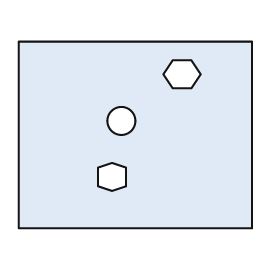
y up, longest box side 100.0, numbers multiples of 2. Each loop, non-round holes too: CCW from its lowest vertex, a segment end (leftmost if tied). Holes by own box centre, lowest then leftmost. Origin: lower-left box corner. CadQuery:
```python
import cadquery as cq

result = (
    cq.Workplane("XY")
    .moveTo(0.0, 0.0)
    .lineTo(100.0, 0.0)
    .lineTo(100.0, 80.0)
    .lineTo(0.0, 80.0)
    .close()
    .moveTo(40.0, 16.0)
    .lineTo(46.0, 18.0)
    .lineTo(46.0, 26.0)
    .lineTo(40.0, 28.0)
    .lineTo(34.0, 26.0)
    .lineTo(34.0, 18.0)
    .close()
    .moveTo(44.0, 46.0)
    .circle(6.0)
    .moveTo(66.0, 60.0)
    .lineTo(74.0, 60.0)
    .lineTo(78.0, 66.0)
    .lineTo(74.0, 72.0)
    .lineTo(66.0, 72.0)
    .lineTo(62.0, 66.0)
    .close()
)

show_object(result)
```